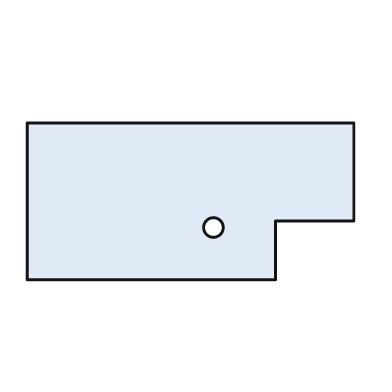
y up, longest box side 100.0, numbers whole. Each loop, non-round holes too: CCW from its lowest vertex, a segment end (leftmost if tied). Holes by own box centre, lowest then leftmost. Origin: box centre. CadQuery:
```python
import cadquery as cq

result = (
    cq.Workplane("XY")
    .moveTo(-50.0, -24.0)
    .lineTo(26.0, -24.0)
    .lineTo(26.0, -6.0)
    .lineTo(50.0, -6.0)
    .lineTo(50.0, 24.0)
    .lineTo(-50.0, 24.0)
    .close()
    .moveTo(7.0, -8.0)
    .circle(3.0)
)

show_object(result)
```